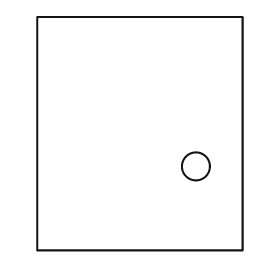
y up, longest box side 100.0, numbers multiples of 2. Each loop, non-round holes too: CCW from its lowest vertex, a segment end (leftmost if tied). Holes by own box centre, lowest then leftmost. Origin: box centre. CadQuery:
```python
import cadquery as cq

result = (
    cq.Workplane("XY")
    .moveTo(-44.0, -50.0)
    .lineTo(44.0, -50.0)
    .lineTo(44.0, 50.0)
    .lineTo(-44.0, 50.0)
    .close()
    .moveTo(24.0, -14.0)
    .circle(6.0)
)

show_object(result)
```